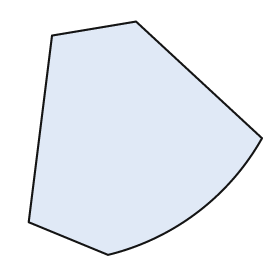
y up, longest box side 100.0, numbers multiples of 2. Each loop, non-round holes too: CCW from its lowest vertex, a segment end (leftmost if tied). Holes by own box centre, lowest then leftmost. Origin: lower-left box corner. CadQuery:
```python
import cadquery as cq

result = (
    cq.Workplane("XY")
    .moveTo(34.0, 0.0)
    .threePointArc((72.0, 18.0), (100.0, 50.0))
    .lineTo(46.0, 100.0)
    .lineTo(10.0, 94.0)
    .lineTo(0.0, 14.0)
    .close()
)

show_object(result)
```